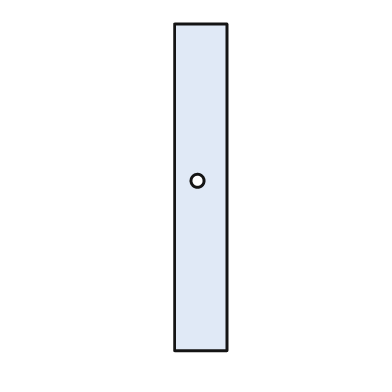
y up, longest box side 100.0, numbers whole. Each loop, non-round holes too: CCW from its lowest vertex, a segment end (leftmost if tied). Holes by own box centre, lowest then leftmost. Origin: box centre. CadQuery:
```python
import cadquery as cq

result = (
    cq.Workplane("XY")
    .moveTo(-8.0, -50.0)
    .lineTo(8.0, -50.0)
    .lineTo(8.0, 50.0)
    .lineTo(-8.0, 50.0)
    .close()
    .moveTo(-1.0, 2.0)
    .circle(2.0)
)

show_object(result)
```